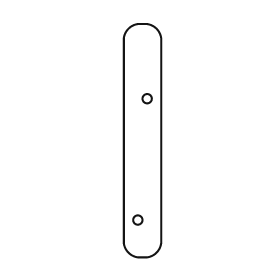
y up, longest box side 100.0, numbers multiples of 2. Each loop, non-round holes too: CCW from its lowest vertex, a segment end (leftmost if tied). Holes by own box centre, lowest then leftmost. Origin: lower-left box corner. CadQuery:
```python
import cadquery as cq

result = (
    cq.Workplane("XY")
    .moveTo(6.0, 0.0)
    .lineTo(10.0, 0.0)
    .threePointArc((14.0, 2.0), (16.0, 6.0))
    .lineTo(16.0, 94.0)
    .threePointArc((14.0, 98.0), (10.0, 100.0))
    .lineTo(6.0, 100.0)
    .threePointArc((2.0, 98.0), (0.0, 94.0))
    .lineTo(0.0, 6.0)
    .threePointArc((2.0, 2.0), (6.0, 0.0))
    .close()
    .moveTo(6.0, 16.0)
    .circle(2.0)
    .moveTo(10.0, 68.0)
    .circle(2.0)
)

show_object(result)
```